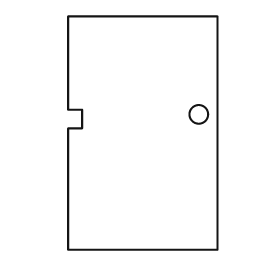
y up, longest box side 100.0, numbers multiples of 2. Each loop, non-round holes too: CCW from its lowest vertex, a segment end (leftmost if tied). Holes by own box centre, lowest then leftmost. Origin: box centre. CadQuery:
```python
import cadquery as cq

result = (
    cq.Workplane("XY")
    .moveTo(-32.0, -50.0)
    .lineTo(32.0, -50.0)
    .lineTo(32.0, 50.0)
    .lineTo(-32.0, 50.0)
    .lineTo(-32.0, 10.0)
    .lineTo(-26.0, 10.0)
    .lineTo(-26.0, 2.0)
    .lineTo(-32.0, 2.0)
    .close()
    .moveTo(24.0, 8.0)
    .circle(4.0)
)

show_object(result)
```